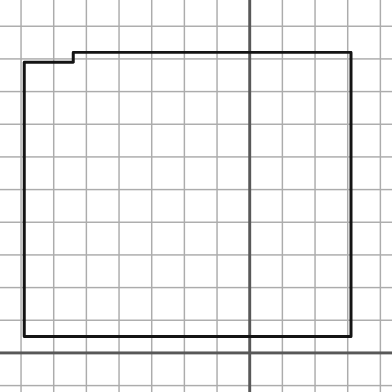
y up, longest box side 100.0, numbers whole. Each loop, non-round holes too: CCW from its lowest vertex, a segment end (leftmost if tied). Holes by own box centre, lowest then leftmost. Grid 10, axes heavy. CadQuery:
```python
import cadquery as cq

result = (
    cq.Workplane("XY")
    .moveTo(-69.0, 5.0)
    .lineTo(31.0, 5.0)
    .lineTo(31.0, 92.0)
    .lineTo(-54.0, 92.0)
    .lineTo(-54.0, 89.0)
    .lineTo(-69.0, 89.0)
    .close()
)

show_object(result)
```